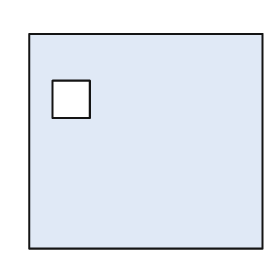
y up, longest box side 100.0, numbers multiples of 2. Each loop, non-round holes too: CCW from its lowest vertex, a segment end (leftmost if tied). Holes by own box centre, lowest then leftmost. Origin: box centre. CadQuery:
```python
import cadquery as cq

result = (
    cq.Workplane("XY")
    .moveTo(-50.0, -46.0)
    .lineTo(50.0, -46.0)
    .lineTo(50.0, 46.0)
    .lineTo(-50.0, 46.0)
    .close()
    .moveTo(-40.0, 10.0)
    .lineTo(-24.0, 10.0)
    .lineTo(-24.0, 26.0)
    .lineTo(-40.0, 26.0)
    .close()
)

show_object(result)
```